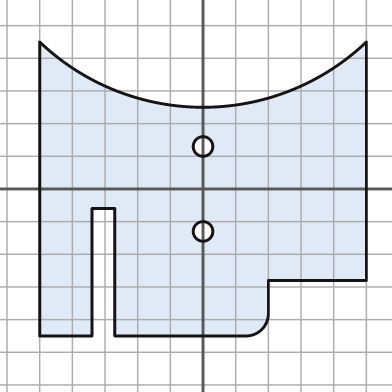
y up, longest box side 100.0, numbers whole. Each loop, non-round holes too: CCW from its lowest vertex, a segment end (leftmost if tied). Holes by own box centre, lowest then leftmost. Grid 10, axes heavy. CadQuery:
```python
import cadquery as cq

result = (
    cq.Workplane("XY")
    .moveTo(-50.0, -45.0)
    .lineTo(-34.0, -45.0)
    .lineTo(-34.0, -6.0)
    .lineTo(-27.0, -6.0)
    .lineTo(-27.0, -45.0)
    .lineTo(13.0, -45.0)
    .threePointArc((18.0, -43.0), (20.0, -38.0))
    .lineTo(20.0, -28.0)
    .lineTo(50.0, -28.0)
    .lineTo(50.0, 45.0)
    .threePointArc((0.0, 25.0), (-50.0, 45.0))
    .close()
    .moveTo(0.0, -13.0)
    .circle(3.0)
    .moveTo(0.0, 13.0)
    .circle(3.0)
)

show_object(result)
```